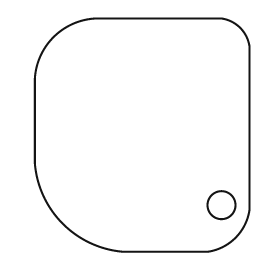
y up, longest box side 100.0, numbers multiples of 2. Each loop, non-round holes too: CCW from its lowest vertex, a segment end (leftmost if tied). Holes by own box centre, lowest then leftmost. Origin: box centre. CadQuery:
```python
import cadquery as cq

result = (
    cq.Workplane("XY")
    .moveTo(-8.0, -50.0)
    .lineTo(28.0, -50.0)
    .threePointArc((40.0, -44.0), (46.0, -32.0))
    .lineTo(46.0, 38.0)
    .threePointArc((42.0, 46.0), (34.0, 50.0))
    .lineTo(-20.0, 50.0)
    .threePointArc((-38.0, 42.0), (-46.0, 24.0))
    .lineTo(-46.0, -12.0)
    .threePointArc((-34.0, -38.0), (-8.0, -50.0))
    .close()
    .moveTo(34.0, -30.0)
    .circle(6.0)
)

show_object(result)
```